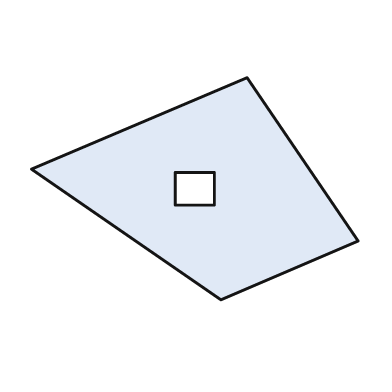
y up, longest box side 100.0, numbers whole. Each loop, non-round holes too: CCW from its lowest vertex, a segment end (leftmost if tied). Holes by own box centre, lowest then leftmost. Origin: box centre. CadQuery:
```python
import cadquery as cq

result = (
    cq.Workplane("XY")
    .moveTo(8.0, -34.0)
    .lineTo(50.0, -16.0)
    .lineTo(16.0, 34.0)
    .lineTo(-50.0, 6.0)
    .close()
    .moveTo(-6.0, -5.0)
    .lineTo(6.0, -5.0)
    .lineTo(6.0, 5.0)
    .lineTo(-6.0, 5.0)
    .close()
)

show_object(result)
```